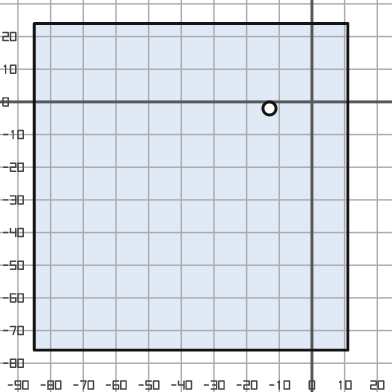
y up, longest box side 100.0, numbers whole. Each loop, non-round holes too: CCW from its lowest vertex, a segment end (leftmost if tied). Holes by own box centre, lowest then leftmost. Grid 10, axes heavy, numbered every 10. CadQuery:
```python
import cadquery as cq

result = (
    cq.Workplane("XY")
    .moveTo(-85.0, -76.0)
    .lineTo(11.0, -76.0)
    .lineTo(11.0, 24.0)
    .lineTo(-85.0, 24.0)
    .close()
    .moveTo(-13.0, -2.0)
    .circle(2.0)
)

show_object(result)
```